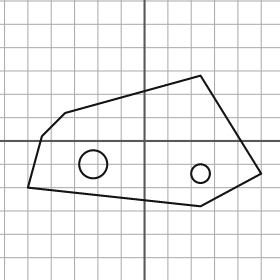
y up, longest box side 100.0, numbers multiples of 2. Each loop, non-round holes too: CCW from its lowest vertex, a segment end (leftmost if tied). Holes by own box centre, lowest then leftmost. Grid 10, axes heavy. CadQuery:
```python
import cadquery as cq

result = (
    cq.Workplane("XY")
    .moveTo(24.0, -28.0)
    .lineTo(50.0, -14.0)
    .lineTo(24.0, 28.0)
    .lineTo(-34.0, 12.0)
    .lineTo(-44.0, 2.0)
    .lineTo(-50.0, -20.0)
    .close()
    .moveTo(24.0, -14.0)
    .circle(4.0)
    .moveTo(-22.0, -10.0)
    .circle(6.0)
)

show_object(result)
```